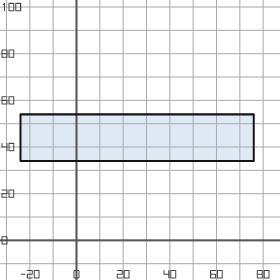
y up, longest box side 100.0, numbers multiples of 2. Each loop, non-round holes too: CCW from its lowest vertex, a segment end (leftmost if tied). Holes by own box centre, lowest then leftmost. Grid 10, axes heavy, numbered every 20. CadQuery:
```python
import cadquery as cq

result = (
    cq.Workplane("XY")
    .moveTo(-24.0, 34.0)
    .lineTo(76.0, 34.0)
    .lineTo(76.0, 54.0)
    .lineTo(-24.0, 54.0)
    .close()
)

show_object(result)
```